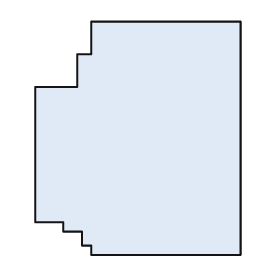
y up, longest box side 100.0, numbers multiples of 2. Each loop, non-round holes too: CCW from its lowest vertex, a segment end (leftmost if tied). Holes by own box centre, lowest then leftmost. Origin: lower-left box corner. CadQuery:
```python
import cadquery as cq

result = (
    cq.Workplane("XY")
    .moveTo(24.0, 0.0)
    .lineTo(88.0, 0.0)
    .lineTo(88.0, 100.0)
    .lineTo(24.0, 100.0)
    .lineTo(24.0, 86.0)
    .lineTo(18.0, 86.0)
    .lineTo(18.0, 72.0)
    .lineTo(0.0, 72.0)
    .lineTo(0.0, 14.0)
    .lineTo(12.0, 14.0)
    .lineTo(12.0, 10.0)
    .lineTo(20.0, 10.0)
    .lineTo(20.0, 4.0)
    .lineTo(24.0, 4.0)
    .close()
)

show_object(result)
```